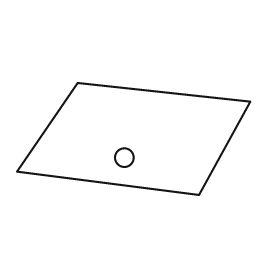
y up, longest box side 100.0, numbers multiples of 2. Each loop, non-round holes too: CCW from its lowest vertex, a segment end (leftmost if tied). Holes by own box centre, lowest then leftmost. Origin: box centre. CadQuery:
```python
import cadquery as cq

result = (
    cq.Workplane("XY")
    .moveTo(28.0, -24.0)
    .lineTo(50.0, 16.0)
    .lineTo(-24.0, 24.0)
    .lineTo(-50.0, -14.0)
    .close()
    .moveTo(-4.0, -8.0)
    .circle(4.0)
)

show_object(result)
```